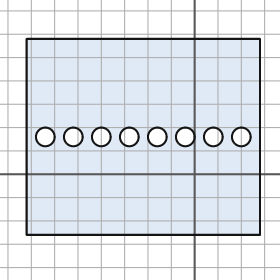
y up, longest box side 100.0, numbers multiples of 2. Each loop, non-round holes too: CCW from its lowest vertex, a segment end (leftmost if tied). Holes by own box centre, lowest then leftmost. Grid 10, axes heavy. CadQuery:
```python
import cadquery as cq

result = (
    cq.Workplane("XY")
    .moveTo(-72.0, -26.0)
    .lineTo(28.0, -26.0)
    .lineTo(28.0, 58.0)
    .lineTo(-72.0, 58.0)
    .close()
    .moveTo(-64.0, 16.0)
    .circle(4.0)
    .moveTo(-52.0, 16.0)
    .circle(4.0)
    .moveTo(-40.0, 16.0)
    .circle(4.0)
    .moveTo(-28.0, 16.0)
    .circle(4.0)
    .moveTo(-16.0, 16.0)
    .circle(4.0)
    .moveTo(-4.0, 16.0)
    .circle(4.0)
    .moveTo(8.0, 16.0)
    .circle(4.0)
    .moveTo(20.0, 16.0)
    .circle(4.0)
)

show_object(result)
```